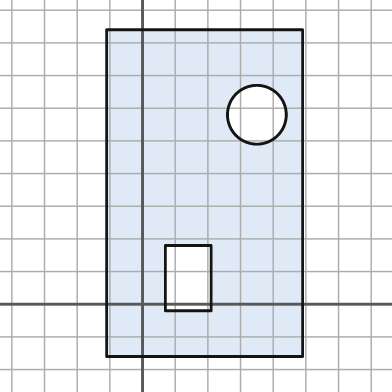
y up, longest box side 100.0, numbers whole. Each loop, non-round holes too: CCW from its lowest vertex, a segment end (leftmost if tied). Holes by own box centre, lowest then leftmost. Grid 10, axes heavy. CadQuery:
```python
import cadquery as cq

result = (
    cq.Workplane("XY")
    .moveTo(-11.0, -16.0)
    .lineTo(49.0, -16.0)
    .lineTo(49.0, 84.0)
    .lineTo(-11.0, 84.0)
    .close()
    .moveTo(7.0, -2.0)
    .lineTo(21.0, -2.0)
    .lineTo(21.0, 18.0)
    .lineTo(7.0, 18.0)
    .close()
    .moveTo(35.0, 58.0)
    .circle(9.0)
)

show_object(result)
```